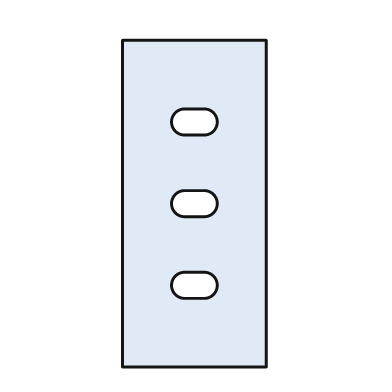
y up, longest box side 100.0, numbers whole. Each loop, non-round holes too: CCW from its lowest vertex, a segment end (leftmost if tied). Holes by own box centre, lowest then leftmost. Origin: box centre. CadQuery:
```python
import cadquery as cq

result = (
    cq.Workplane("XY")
    .moveTo(-22.0, -50.0)
    .lineTo(22.0, -50.0)
    .lineTo(22.0, 50.0)
    .lineTo(-22.0, 50.0)
    .close()
    .moveTo(-3.0, -29.0)
    .lineTo(3.0, -29.0)
    .threePointArc((7.0, -25.0), (3.0, -21.0))
    .lineTo(-3.0, -21.0)
    .threePointArc((-7.0, -25.0), (-3.0, -29.0))
    .close()
    .moveTo(-3.0, -4.0)
    .lineTo(3.0, -4.0)
    .threePointArc((7.0, 0.0), (3.0, 4.0))
    .lineTo(-3.0, 4.0)
    .threePointArc((-7.0, 0.0), (-3.0, -4.0))
    .close()
    .moveTo(-3.0, 21.0)
    .lineTo(3.0, 21.0)
    .threePointArc((7.0, 25.0), (3.0, 29.0))
    .lineTo(-3.0, 29.0)
    .threePointArc((-7.0, 25.0), (-3.0, 21.0))
    .close()
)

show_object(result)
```